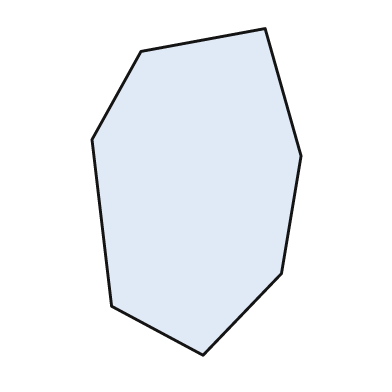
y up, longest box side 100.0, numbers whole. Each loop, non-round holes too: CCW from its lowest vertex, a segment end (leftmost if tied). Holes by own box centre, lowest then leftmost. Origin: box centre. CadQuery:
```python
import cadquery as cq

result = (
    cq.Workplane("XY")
    .moveTo(2.0, -50.0)
    .lineTo(26.0, -25.0)
    .lineTo(32.0, 11.0)
    .lineTo(21.0, 50.0)
    .lineTo(-17.0, 43.0)
    .lineTo(-32.0, 16.0)
    .lineTo(-26.0, -35.0)
    .close()
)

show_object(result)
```